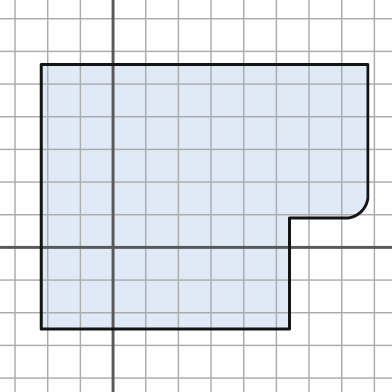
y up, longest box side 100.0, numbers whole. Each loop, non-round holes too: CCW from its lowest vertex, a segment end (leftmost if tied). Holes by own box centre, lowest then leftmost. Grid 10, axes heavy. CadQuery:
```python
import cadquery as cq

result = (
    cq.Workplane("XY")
    .moveTo(-22.0, -25.0)
    .lineTo(54.0, -25.0)
    .lineTo(54.0, 9.0)
    .lineTo(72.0, 9.0)
    .threePointArc((76.0, 11.0), (78.0, 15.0))
    .lineTo(78.0, 56.0)
    .lineTo(-22.0, 56.0)
    .close()
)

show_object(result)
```